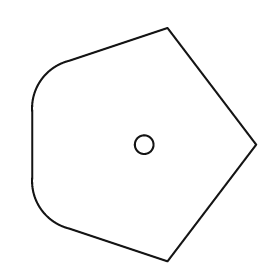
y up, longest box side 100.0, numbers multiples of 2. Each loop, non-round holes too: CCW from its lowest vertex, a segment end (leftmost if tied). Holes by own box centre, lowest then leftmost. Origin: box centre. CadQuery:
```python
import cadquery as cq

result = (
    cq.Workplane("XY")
    .moveTo(10.0, -50.0)
    .lineTo(48.0, 0.0)
    .lineTo(10.0, 50.0)
    .lineTo(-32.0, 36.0)
    .threePointArc((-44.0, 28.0), (-48.0, 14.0))
    .lineTo(-48.0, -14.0)
    .threePointArc((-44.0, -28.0), (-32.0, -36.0))
    .close()
    .moveTo(0.0, 0.0)
    .circle(4.0)
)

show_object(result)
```